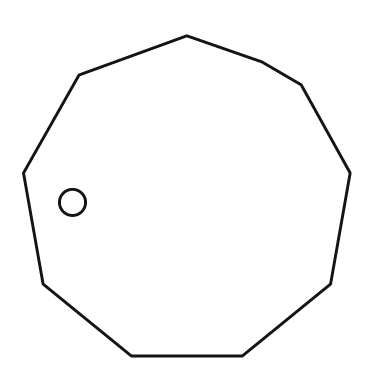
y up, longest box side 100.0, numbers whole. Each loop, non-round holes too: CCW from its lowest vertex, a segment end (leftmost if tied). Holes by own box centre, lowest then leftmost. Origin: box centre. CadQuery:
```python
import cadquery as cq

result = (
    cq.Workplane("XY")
    .moveTo(-17.0, -49.0)
    .lineTo(17.0, -49.0)
    .lineTo(44.0, -27.0)
    .lineTo(50.0, 7.0)
    .lineTo(35.0, 34.0)
    .lineTo(23.0, 41.0)
    .lineTo(0.0, 49.0)
    .lineTo(-33.0, 37.0)
    .lineTo(-50.0, 7.0)
    .lineTo(-44.0, -27.0)
    .close()
    .moveTo(-35.0, -2.0)
    .circle(4.0)
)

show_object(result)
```